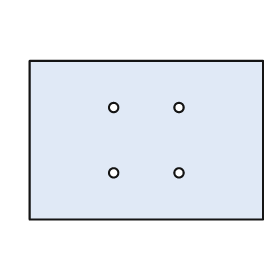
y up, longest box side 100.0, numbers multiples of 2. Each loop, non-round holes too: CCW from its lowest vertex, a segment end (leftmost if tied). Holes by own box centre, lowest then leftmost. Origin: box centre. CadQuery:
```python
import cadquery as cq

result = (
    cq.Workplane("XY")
    .moveTo(-50.0, -34.0)
    .lineTo(50.0, -34.0)
    .lineTo(50.0, 34.0)
    .lineTo(-50.0, 34.0)
    .close()
    .moveTo(-14.0, -14.0)
    .circle(2.0)
    .moveTo(14.0, -14.0)
    .circle(2.0)
    .moveTo(-14.0, 14.0)
    .circle(2.0)
    .moveTo(14.0, 14.0)
    .circle(2.0)
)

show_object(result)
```